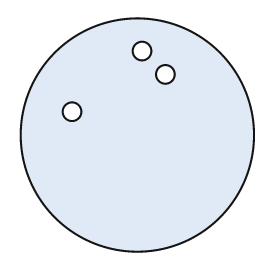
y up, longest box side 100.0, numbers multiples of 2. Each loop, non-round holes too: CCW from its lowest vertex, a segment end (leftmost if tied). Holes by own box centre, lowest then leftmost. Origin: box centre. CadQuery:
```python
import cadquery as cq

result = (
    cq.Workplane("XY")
    .moveTo(0.0, 0.0)
    .circle(50.0)
    .moveTo(-28.0, 10.0)
    .circle(4.0)
    .moveTo(12.0, 26.0)
    .circle(4.0)
    .moveTo(2.0, 36.0)
    .circle(4.0)
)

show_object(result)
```